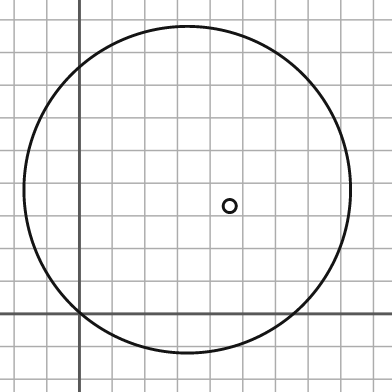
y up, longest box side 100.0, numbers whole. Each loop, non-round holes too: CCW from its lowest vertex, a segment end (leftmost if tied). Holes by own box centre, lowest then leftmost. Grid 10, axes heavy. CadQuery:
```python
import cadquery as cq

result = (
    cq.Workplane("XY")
    .moveTo(33.0, 38.0)
    .circle(50.0)
    .moveTo(46.0, 33.0)
    .circle(2.0)
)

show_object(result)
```